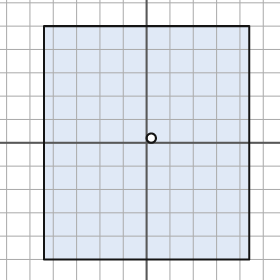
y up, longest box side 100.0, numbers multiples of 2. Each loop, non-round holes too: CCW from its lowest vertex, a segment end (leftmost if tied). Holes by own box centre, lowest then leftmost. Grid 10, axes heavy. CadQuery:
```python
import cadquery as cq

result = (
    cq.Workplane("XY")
    .moveTo(-44.0, -50.0)
    .lineTo(44.0, -50.0)
    .lineTo(44.0, 50.0)
    .lineTo(-44.0, 50.0)
    .close()
    .moveTo(2.0, 2.0)
    .circle(2.0)
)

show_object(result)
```